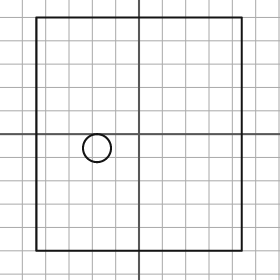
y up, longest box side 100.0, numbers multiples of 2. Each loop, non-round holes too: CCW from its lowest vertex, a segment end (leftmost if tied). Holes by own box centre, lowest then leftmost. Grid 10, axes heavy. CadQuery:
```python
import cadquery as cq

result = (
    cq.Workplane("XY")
    .moveTo(-44.0, -50.0)
    .lineTo(44.0, -50.0)
    .lineTo(44.0, 50.0)
    .lineTo(-44.0, 50.0)
    .close()
    .moveTo(-18.0, -6.0)
    .circle(6.0)
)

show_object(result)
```